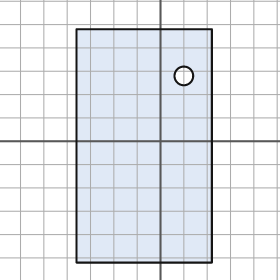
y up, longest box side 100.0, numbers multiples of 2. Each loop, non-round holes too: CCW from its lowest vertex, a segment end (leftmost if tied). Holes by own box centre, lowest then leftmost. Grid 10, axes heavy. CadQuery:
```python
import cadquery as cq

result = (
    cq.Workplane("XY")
    .moveTo(-36.0, -52.0)
    .lineTo(22.0, -52.0)
    .lineTo(22.0, 48.0)
    .lineTo(-36.0, 48.0)
    .close()
    .moveTo(10.0, 28.0)
    .circle(4.0)
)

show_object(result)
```